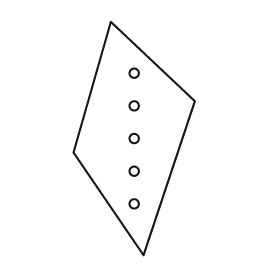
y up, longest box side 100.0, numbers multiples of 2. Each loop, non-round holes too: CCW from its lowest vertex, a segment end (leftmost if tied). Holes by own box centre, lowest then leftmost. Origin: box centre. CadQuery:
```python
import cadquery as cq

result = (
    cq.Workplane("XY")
    .moveTo(4.0, -50.0)
    .lineTo(26.0, 16.0)
    .lineTo(-10.0, 50.0)
    .lineTo(-26.0, -6.0)
    .close()
    .moveTo(0.0, -28.0)
    .circle(2.0)
    .moveTo(0.0, -14.0)
    .circle(2.0)
    .moveTo(0.0, 0.0)
    .circle(2.0)
    .moveTo(0.0, 14.0)
    .circle(2.0)
    .moveTo(0.0, 28.0)
    .circle(2.0)
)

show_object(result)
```